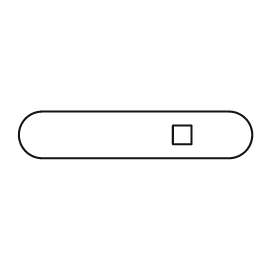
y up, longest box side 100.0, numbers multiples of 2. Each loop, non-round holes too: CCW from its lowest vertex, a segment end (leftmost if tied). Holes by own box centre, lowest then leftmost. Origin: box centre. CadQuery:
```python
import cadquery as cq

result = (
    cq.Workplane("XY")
    .moveTo(-40.0, -10.0)
    .lineTo(40.0, -10.0)
    .threePointArc((50.0, 0.0), (40.0, 10.0))
    .lineTo(-40.0, 10.0)
    .threePointArc((-50.0, 0.0), (-40.0, -10.0))
    .close()
    .moveTo(16.0, -4.0)
    .lineTo(24.0, -4.0)
    .lineTo(24.0, 4.0)
    .lineTo(16.0, 4.0)
    .close()
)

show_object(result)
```